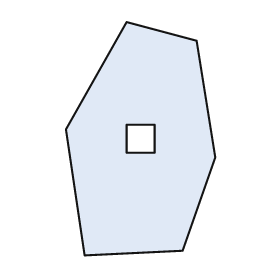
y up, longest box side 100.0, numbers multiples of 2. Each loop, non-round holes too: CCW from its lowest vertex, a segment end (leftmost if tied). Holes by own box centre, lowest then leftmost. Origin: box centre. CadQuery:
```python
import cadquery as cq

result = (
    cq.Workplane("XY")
    .moveTo(-24.0, -50.0)
    .lineTo(18.0, -48.0)
    .lineTo(32.0, -8.0)
    .lineTo(24.0, 42.0)
    .lineTo(-6.0, 50.0)
    .lineTo(-32.0, 4.0)
    .close()
    .moveTo(-6.0, -6.0)
    .lineTo(6.0, -6.0)
    .lineTo(6.0, 6.0)
    .lineTo(-6.0, 6.0)
    .close()
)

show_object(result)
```